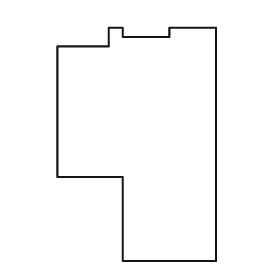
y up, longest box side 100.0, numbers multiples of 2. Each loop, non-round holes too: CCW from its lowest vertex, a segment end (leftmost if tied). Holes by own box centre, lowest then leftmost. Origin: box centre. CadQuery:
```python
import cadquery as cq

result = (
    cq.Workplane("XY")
    .moveTo(-6.0, -50.0)
    .lineTo(34.0, -50.0)
    .lineTo(34.0, 50.0)
    .lineTo(14.0, 50.0)
    .lineTo(14.0, 46.0)
    .lineTo(-6.0, 46.0)
    .lineTo(-6.0, 50.0)
    .lineTo(-12.0, 50.0)
    .lineTo(-12.0, 42.0)
    .lineTo(-34.0, 42.0)
    .lineTo(-34.0, -14.0)
    .lineTo(-6.0, -14.0)
    .close()
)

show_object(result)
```